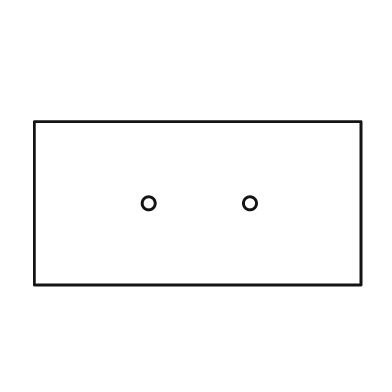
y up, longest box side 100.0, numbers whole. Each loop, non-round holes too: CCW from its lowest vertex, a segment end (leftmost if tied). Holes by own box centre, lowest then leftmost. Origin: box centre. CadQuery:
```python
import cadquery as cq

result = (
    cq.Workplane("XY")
    .moveTo(-50.0, -25.0)
    .lineTo(50.0, -25.0)
    .lineTo(50.0, 25.0)
    .lineTo(-50.0, 25.0)
    .close()
    .moveTo(-15.0, 0.0)
    .circle(2.0)
    .moveTo(16.0, 0.0)
    .circle(2.0)
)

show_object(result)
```